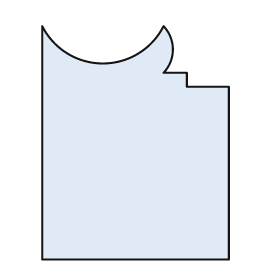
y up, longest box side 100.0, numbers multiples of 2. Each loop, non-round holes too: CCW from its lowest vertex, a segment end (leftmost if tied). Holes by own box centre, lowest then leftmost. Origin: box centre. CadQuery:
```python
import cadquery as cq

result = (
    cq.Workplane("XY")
    .moveTo(-40.0, -50.0)
    .lineTo(40.0, -50.0)
    .lineTo(40.0, 24.0)
    .lineTo(22.0, 24.0)
    .lineTo(22.0, 30.0)
    .lineTo(12.0, 30.0)
    .threePointArc((16.0, 40.0), (12.0, 50.0))
    .threePointArc((-14.0, 34.0), (-40.0, 50.0))
    .close()
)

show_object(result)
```